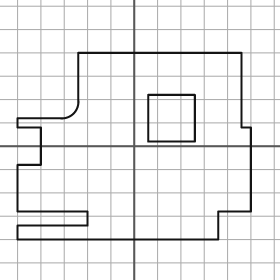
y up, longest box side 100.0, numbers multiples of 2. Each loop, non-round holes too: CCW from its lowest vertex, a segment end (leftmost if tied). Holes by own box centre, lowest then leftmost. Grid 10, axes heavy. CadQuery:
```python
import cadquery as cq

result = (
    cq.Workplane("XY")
    .moveTo(-50.0, -40.0)
    .lineTo(36.0, -40.0)
    .lineTo(36.0, -28.0)
    .lineTo(50.0, -28.0)
    .lineTo(50.0, 8.0)
    .lineTo(46.0, 8.0)
    .lineTo(46.0, 40.0)
    .lineTo(-24.0, 40.0)
    .lineTo(-24.0, 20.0)
    .threePointArc((-26.0, 14.0), (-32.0, 12.0))
    .lineTo(-50.0, 12.0)
    .lineTo(-50.0, 8.0)
    .lineTo(-40.0, 8.0)
    .lineTo(-40.0, -8.0)
    .lineTo(-50.0, -8.0)
    .lineTo(-50.0, -28.0)
    .lineTo(-20.0, -28.0)
    .lineTo(-20.0, -34.0)
    .lineTo(-50.0, -34.0)
    .close()
    .moveTo(6.0, 2.0)
    .lineTo(26.0, 2.0)
    .lineTo(26.0, 22.0)
    .lineTo(6.0, 22.0)
    .close()
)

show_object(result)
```